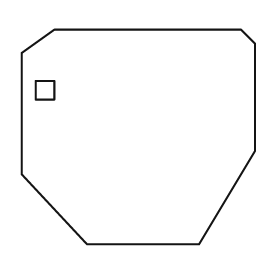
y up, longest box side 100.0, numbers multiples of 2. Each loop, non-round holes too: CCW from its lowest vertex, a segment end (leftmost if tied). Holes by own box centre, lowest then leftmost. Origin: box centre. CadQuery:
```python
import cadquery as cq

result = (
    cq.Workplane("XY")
    .moveTo(-22.0, -46.0)
    .lineTo(26.0, -46.0)
    .lineTo(50.0, -6.0)
    .lineTo(50.0, 40.0)
    .lineTo(44.0, 46.0)
    .lineTo(-36.0, 46.0)
    .lineTo(-50.0, 36.0)
    .lineTo(-50.0, -16.0)
    .close()
    .moveTo(-44.0, 16.0)
    .lineTo(-36.0, 16.0)
    .lineTo(-36.0, 24.0)
    .lineTo(-44.0, 24.0)
    .close()
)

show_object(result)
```